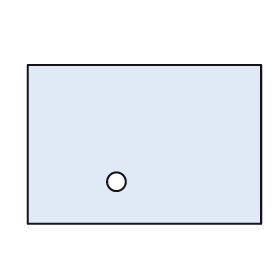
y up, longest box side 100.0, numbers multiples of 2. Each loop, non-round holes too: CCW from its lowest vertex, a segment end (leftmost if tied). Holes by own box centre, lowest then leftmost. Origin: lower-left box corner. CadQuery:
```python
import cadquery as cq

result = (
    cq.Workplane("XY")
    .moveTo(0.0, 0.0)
    .lineTo(100.0, 0.0)
    .lineTo(100.0, 68.0)
    .lineTo(0.0, 68.0)
    .close()
    .moveTo(38.0, 18.0)
    .circle(4.0)
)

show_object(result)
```